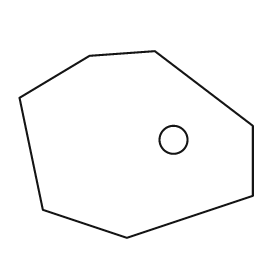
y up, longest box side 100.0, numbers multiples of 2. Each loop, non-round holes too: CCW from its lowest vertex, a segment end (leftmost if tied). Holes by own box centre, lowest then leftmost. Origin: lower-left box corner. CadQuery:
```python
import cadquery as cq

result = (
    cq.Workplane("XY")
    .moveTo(46.0, 0.0)
    .lineTo(100.0, 18.0)
    .lineTo(100.0, 48.0)
    .lineTo(58.0, 80.0)
    .lineTo(30.0, 78.0)
    .lineTo(0.0, 60.0)
    .lineTo(10.0, 12.0)
    .close()
    .moveTo(66.0, 42.0)
    .circle(6.0)
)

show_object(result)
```